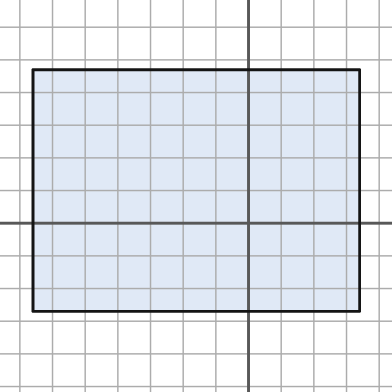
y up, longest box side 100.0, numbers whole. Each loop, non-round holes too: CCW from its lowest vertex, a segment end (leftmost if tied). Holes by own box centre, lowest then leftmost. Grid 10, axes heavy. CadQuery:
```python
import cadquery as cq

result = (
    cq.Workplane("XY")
    .moveTo(-66.0, -27.0)
    .lineTo(34.0, -27.0)
    .lineTo(34.0, 47.0)
    .lineTo(-66.0, 47.0)
    .close()
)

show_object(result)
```